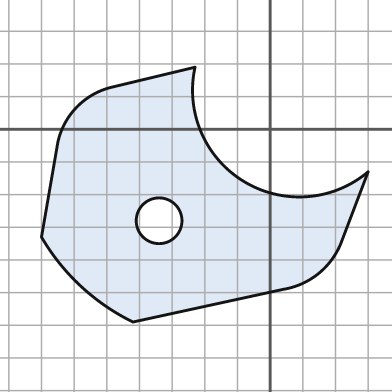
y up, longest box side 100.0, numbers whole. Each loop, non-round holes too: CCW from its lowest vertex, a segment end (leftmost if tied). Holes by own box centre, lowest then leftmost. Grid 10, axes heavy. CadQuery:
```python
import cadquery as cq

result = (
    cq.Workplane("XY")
    .moveTo(-42.0, -59.0)
    .lineTo(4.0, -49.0)
    .threePointArc((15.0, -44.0), (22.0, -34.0))
    .lineTo(30.0, -13.0)
    .threePointArc((-8.0, -16.0), (-23.0, 19.0))
    .lineTo(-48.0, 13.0)
    .threePointArc((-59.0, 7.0), (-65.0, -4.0))
    .lineTo(-70.0, -33.0)
    .threePointArc((-58.0, -48.0), (-42.0, -59.0))
    .close()
    .moveTo(-34.0, -28.0)
    .circle(7.0)
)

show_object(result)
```